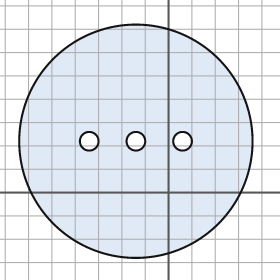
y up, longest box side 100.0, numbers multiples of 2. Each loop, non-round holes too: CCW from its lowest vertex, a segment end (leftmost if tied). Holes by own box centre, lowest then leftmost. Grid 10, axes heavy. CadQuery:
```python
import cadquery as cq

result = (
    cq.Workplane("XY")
    .moveTo(-14.0, 22.0)
    .circle(50.0)
    .moveTo(-34.0, 22.0)
    .circle(4.0)
    .moveTo(-14.0, 22.0)
    .circle(4.0)
    .moveTo(6.0, 22.0)
    .circle(4.0)
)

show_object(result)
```